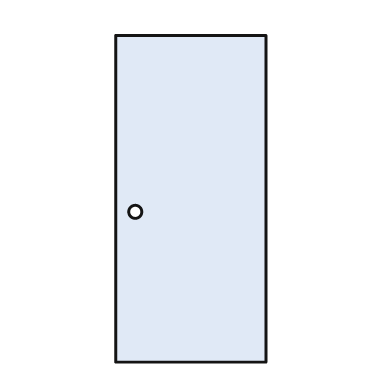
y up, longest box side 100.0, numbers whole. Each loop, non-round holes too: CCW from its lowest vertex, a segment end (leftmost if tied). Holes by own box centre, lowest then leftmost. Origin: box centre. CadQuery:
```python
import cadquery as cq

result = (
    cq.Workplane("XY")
    .moveTo(-23.0, -50.0)
    .lineTo(23.0, -50.0)
    .lineTo(23.0, 50.0)
    .lineTo(-23.0, 50.0)
    .close()
    .moveTo(-17.0, -4.0)
    .circle(2.0)
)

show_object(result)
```